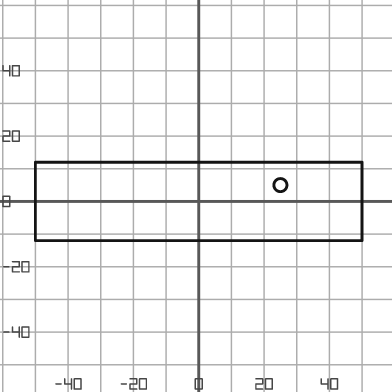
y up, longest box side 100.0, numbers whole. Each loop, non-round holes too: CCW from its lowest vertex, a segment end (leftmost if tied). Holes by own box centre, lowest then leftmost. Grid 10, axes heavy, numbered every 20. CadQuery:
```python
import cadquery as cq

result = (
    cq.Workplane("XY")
    .moveTo(-50.0, -12.0)
    .lineTo(50.0, -12.0)
    .lineTo(50.0, 12.0)
    .lineTo(-50.0, 12.0)
    .close()
    .moveTo(25.0, 5.0)
    .circle(2.0)
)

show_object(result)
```